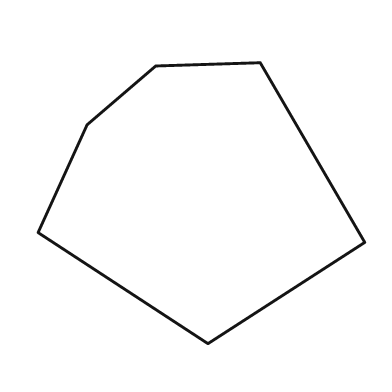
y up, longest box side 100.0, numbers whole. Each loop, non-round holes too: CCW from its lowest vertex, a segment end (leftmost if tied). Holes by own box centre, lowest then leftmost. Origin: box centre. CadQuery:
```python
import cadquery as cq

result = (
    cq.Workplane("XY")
    .moveTo(2.0, -43.0)
    .lineTo(50.0, -12.0)
    .lineTo(18.0, 43.0)
    .lineTo(-14.0, 42.0)
    .lineTo(-35.0, 24.0)
    .lineTo(-50.0, -9.0)
    .close()
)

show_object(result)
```